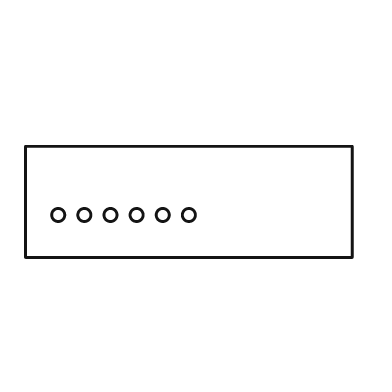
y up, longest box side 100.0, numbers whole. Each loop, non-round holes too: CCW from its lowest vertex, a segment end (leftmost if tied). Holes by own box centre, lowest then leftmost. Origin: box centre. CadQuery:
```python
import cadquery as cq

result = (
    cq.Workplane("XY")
    .moveTo(-50.0, -17.0)
    .lineTo(50.0, -17.0)
    .lineTo(50.0, 17.0)
    .lineTo(-50.0, 17.0)
    .close()
    .moveTo(-40.0, -4.0)
    .circle(2.0)
    .moveTo(-32.0, -4.0)
    .circle(2.0)
    .moveTo(-24.0, -4.0)
    .circle(2.0)
    .moveTo(-16.0, -4.0)
    .circle(2.0)
    .moveTo(-8.0, -4.0)
    .circle(2.0)
    .moveTo(0.0, -4.0)
    .circle(2.0)
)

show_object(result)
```